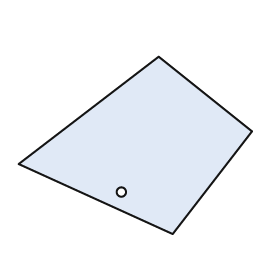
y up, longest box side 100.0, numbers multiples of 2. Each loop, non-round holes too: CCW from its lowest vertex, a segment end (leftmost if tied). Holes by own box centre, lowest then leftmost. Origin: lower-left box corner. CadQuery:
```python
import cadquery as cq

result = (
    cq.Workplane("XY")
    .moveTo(66.0, 0.0)
    .lineTo(100.0, 44.0)
    .lineTo(60.0, 76.0)
    .lineTo(0.0, 30.0)
    .close()
    .moveTo(44.0, 18.0)
    .circle(2.0)
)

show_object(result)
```